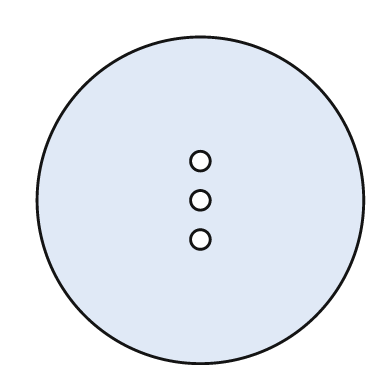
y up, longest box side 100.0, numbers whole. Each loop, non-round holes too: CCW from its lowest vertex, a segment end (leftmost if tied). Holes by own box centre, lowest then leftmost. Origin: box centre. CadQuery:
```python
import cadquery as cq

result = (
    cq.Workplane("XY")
    .moveTo(0.0, 0.0)
    .circle(50.0)
    .moveTo(0.0, -12.0)
    .circle(3.0)
    .moveTo(0.0, 0.0)
    .circle(3.0)
    .moveTo(0.0, 12.0)
    .circle(3.0)
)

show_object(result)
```